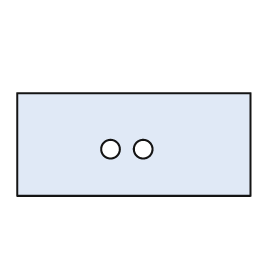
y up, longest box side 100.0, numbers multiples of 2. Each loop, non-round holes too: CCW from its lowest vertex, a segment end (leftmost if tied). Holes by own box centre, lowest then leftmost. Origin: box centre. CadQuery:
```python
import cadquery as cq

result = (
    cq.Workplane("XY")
    .moveTo(-50.0, -22.0)
    .lineTo(50.0, -22.0)
    .lineTo(50.0, 22.0)
    .lineTo(-50.0, 22.0)
    .close()
    .moveTo(-10.0, -2.0)
    .circle(4.0)
    .moveTo(4.0, -2.0)
    .circle(4.0)
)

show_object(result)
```